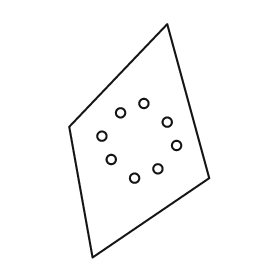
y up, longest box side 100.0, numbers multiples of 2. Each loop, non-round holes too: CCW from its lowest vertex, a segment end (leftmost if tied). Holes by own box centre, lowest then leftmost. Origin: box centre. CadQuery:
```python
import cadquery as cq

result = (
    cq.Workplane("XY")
    .moveTo(-20.0, -50.0)
    .lineTo(30.0, -16.0)
    .lineTo(12.0, 50.0)
    .lineTo(-30.0, 6.0)
    .close()
    .moveTo(-2.0, -16.0)
    .circle(2.0)
    .moveTo(8.0, -12.0)
    .circle(2.0)
    .moveTo(-12.0, -8.0)
    .circle(2.0)
    .moveTo(16.0, -2.0)
    .circle(2.0)
    .moveTo(-16.0, 2.0)
    .circle(2.0)
    .moveTo(12.0, 8.0)
    .circle(2.0)
    .moveTo(-8.0, 12.0)
    .circle(2.0)
    .moveTo(2.0, 16.0)
    .circle(2.0)
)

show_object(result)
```